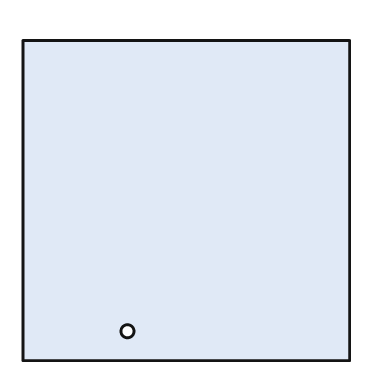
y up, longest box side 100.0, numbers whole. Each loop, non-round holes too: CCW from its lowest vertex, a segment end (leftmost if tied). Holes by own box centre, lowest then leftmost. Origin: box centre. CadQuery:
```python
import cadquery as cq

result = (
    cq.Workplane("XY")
    .moveTo(-50.0, -49.0)
    .lineTo(50.0, -49.0)
    .lineTo(50.0, 49.0)
    .lineTo(-50.0, 49.0)
    .close()
    .moveTo(-18.0, -40.0)
    .circle(2.0)
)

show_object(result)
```